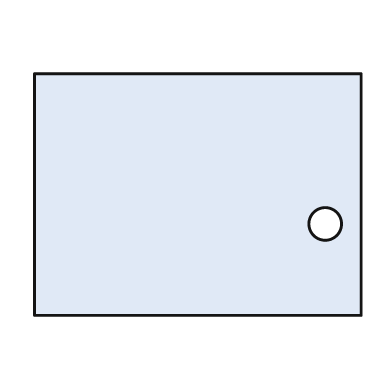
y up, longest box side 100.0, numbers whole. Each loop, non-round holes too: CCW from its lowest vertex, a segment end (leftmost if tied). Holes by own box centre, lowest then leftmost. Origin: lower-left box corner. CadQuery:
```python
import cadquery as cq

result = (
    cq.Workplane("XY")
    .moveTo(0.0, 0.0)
    .lineTo(100.0, 0.0)
    .lineTo(100.0, 74.0)
    .lineTo(0.0, 74.0)
    .close()
    .moveTo(89.0, 28.0)
    .circle(5.0)
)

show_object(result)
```